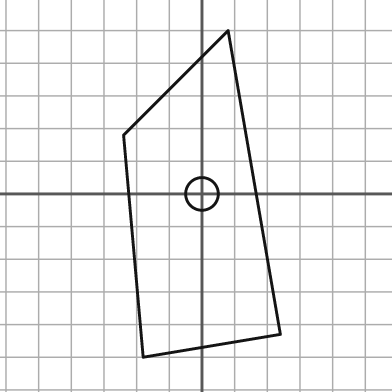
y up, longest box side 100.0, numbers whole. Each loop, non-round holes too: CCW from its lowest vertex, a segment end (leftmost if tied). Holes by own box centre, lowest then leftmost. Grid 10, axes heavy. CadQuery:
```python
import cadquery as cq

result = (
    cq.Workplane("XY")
    .moveTo(-18.0, -50.0)
    .lineTo(24.0, -43.0)
    .lineTo(8.0, 50.0)
    .lineTo(-24.0, 18.0)
    .close()
    .moveTo(0.0, 0.0)
    .circle(5.0)
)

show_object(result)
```